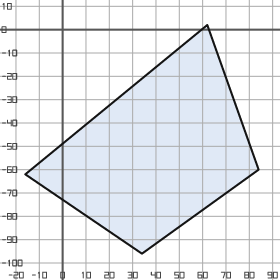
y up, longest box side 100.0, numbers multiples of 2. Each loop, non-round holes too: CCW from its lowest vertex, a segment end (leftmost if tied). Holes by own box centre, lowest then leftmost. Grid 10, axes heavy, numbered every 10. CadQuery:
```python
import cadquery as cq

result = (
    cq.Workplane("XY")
    .moveTo(34.0, -96.0)
    .lineTo(84.0, -60.0)
    .lineTo(62.0, 2.0)
    .lineTo(-16.0, -62.0)
    .close()
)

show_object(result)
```